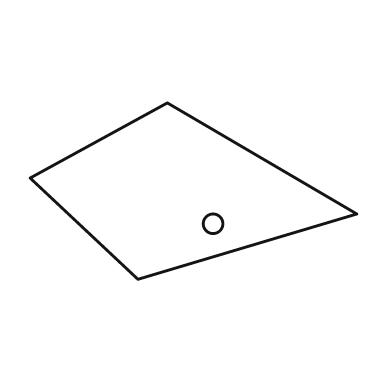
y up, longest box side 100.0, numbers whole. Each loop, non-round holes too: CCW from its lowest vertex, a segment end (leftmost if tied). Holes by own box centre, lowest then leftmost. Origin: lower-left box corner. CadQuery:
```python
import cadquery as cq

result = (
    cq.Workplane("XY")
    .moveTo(33.0, 0.0)
    .lineTo(100.0, 20.0)
    .lineTo(42.0, 54.0)
    .lineTo(0.0, 31.0)
    .close()
    .moveTo(56.0, 17.0)
    .circle(3.0)
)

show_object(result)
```